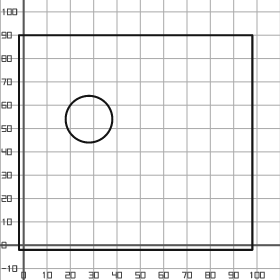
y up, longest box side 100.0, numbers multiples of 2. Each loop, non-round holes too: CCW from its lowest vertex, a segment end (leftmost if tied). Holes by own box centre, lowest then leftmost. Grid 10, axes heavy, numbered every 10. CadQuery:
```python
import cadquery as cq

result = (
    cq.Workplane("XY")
    .moveTo(-2.0, -2.0)
    .lineTo(98.0, -2.0)
    .lineTo(98.0, 90.0)
    .lineTo(-2.0, 90.0)
    .close()
    .moveTo(28.0, 54.0)
    .circle(10.0)
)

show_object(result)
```